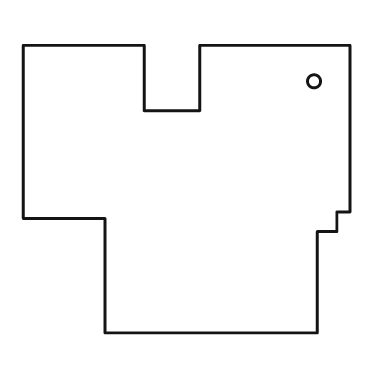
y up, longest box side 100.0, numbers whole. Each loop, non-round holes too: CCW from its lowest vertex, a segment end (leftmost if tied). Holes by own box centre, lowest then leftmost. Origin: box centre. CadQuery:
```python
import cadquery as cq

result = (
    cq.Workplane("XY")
    .moveTo(-25.0, -44.0)
    .lineTo(40.0, -44.0)
    .lineTo(40.0, -13.0)
    .lineTo(46.0, -13.0)
    .lineTo(46.0, -7.0)
    .lineTo(50.0, -7.0)
    .lineTo(50.0, 44.0)
    .lineTo(4.0, 44.0)
    .lineTo(4.0, 24.0)
    .lineTo(-13.0, 24.0)
    .lineTo(-13.0, 44.0)
    .lineTo(-50.0, 44.0)
    .lineTo(-50.0, -9.0)
    .lineTo(-25.0, -9.0)
    .close()
    .moveTo(39.0, 33.0)
    .circle(2.0)
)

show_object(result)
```